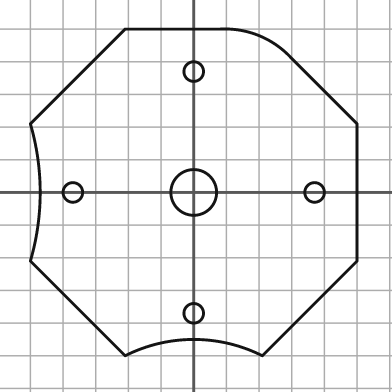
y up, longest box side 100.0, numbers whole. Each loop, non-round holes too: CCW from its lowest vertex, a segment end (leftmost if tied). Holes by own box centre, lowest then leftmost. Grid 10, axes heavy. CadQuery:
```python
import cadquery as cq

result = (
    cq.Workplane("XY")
    .moveTo(-21.0, -50.0)
    .threePointArc((0.0, -45.0), (21.0, -50.0))
    .lineTo(50.0, -21.0)
    .lineTo(50.0, 21.0)
    .lineTo(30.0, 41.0)
    .threePointArc((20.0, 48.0), (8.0, 50.0))
    .lineTo(-21.0, 50.0)
    .lineTo(-50.0, 21.0)
    .threePointArc((-47.0, 0.0), (-50.0, -21.0))
    .close()
    .moveTo(0.0, -37.0)
    .circle(3.0)
    .moveTo(-37.0, 0.0)
    .circle(3.0)
    .moveTo(0.0, 0.0)
    .circle(7.0)
    .moveTo(37.0, 0.0)
    .circle(3.0)
    .moveTo(0.0, 37.0)
    .circle(3.0)
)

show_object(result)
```